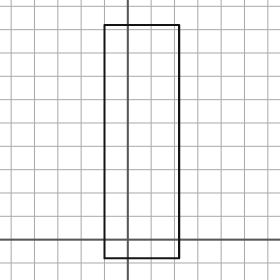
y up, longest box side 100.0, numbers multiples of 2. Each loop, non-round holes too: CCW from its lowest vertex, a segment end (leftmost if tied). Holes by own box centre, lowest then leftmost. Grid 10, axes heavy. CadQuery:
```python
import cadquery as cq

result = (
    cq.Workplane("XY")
    .moveTo(-10.0, -8.0)
    .lineTo(22.0, -8.0)
    .lineTo(22.0, 92.0)
    .lineTo(-10.0, 92.0)
    .close()
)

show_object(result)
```